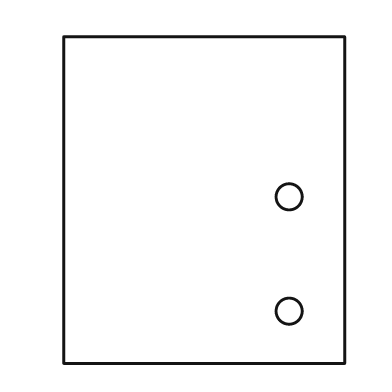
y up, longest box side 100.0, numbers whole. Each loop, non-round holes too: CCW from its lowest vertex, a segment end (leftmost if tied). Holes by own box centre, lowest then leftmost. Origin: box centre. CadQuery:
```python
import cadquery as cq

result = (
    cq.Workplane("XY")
    .moveTo(-43.0, -50.0)
    .lineTo(43.0, -50.0)
    .lineTo(43.0, 50.0)
    .lineTo(-43.0, 50.0)
    .close()
    .moveTo(26.0, -34.0)
    .circle(4.0)
    .moveTo(26.0, 1.0)
    .circle(4.0)
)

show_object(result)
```